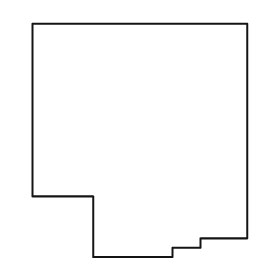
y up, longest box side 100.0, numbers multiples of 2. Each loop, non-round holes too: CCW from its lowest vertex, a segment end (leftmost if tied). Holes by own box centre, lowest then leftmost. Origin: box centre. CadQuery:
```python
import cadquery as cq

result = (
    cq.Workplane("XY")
    .moveTo(-20.0, -50.0)
    .lineTo(14.0, -50.0)
    .lineTo(14.0, -46.0)
    .lineTo(26.0, -46.0)
    .lineTo(26.0, -42.0)
    .lineTo(46.0, -42.0)
    .lineTo(46.0, 50.0)
    .lineTo(-46.0, 50.0)
    .lineTo(-46.0, -24.0)
    .lineTo(-20.0, -24.0)
    .close()
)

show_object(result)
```